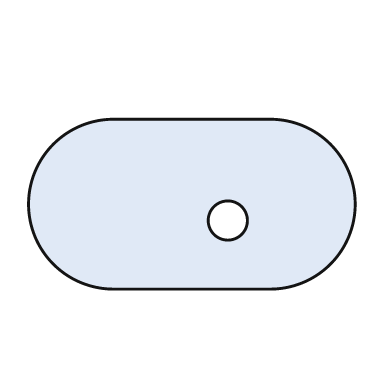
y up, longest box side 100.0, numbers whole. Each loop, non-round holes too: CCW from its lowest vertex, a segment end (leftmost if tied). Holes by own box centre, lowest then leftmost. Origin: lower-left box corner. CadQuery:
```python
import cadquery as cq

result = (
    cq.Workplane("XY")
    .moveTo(26.0, 0.0)
    .lineTo(74.0, 0.0)
    .threePointArc((100.0, 26.0), (74.0, 52.0))
    .lineTo(26.0, 52.0)
    .threePointArc((0.0, 26.0), (26.0, 0.0))
    .close()
    .moveTo(61.0, 21.0)
    .circle(6.0)
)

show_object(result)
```